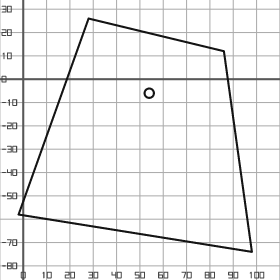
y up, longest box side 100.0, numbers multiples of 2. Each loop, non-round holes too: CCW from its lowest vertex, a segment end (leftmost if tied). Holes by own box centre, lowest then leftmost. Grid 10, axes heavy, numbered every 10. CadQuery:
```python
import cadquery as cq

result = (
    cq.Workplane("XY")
    .moveTo(98.0, -74.0)
    .lineTo(86.0, 12.0)
    .lineTo(28.0, 26.0)
    .lineTo(-2.0, -58.0)
    .close()
    .moveTo(54.0, -6.0)
    .circle(2.0)
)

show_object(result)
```